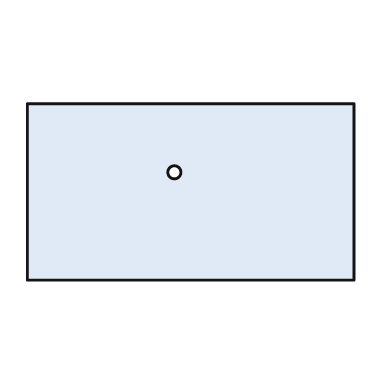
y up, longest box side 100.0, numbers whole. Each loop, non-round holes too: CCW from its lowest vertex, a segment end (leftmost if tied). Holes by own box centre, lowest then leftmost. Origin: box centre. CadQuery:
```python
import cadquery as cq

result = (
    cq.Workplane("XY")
    .moveTo(-50.0, -27.0)
    .lineTo(50.0, -27.0)
    .lineTo(50.0, 27.0)
    .lineTo(-50.0, 27.0)
    .close()
    .moveTo(-5.0, 6.0)
    .circle(2.0)
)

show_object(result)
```